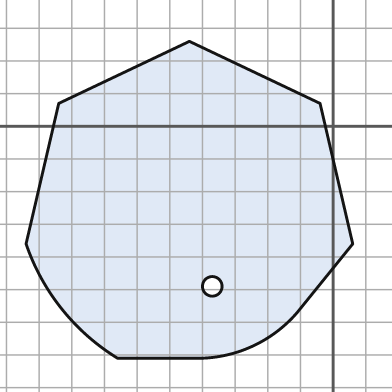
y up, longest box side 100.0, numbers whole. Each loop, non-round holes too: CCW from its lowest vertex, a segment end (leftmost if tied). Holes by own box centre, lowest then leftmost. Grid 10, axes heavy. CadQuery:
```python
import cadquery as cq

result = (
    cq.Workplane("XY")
    .moveTo(-66.0, -71.0)
    .lineTo(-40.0, -71.0)
    .threePointArc((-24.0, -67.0), (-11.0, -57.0))
    .lineTo(6.0, -36.0)
    .lineTo(-4.0, 7.0)
    .lineTo(-44.0, 26.0)
    .lineTo(-84.0, 7.0)
    .lineTo(-94.0, -36.0)
    .threePointArc((-83.0, -56.0), (-66.0, -71.0))
    .close()
    .moveTo(-37.0, -49.0)
    .circle(3.0)
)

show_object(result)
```